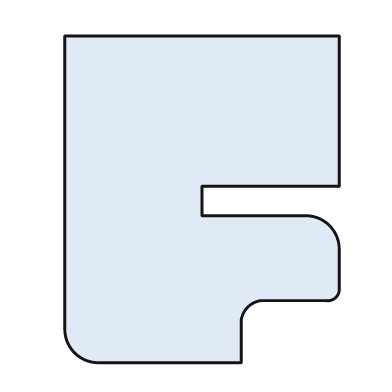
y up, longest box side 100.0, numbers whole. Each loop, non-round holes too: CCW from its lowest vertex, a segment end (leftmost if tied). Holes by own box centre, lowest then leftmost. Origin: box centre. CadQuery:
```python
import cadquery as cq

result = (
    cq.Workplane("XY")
    .moveTo(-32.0, -50.0)
    .lineTo(12.0, -50.0)
    .lineTo(12.0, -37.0)
    .threePointArc((14.0, -33.0), (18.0, -31.0))
    .lineTo(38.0, -31.0)
    .threePointArc((41.0, -30.0), (42.0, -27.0))
    .lineTo(42.0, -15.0)
    .threePointArc((39.0, -8.0), (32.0, -5.0))
    .lineTo(0.0, -5.0)
    .lineTo(0.0, 4.0)
    .lineTo(42.0, 4.0)
    .lineTo(42.0, 50.0)
    .lineTo(-42.0, 50.0)
    .lineTo(-42.0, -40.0)
    .threePointArc((-39.0, -47.0), (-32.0, -50.0))
    .close()
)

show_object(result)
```